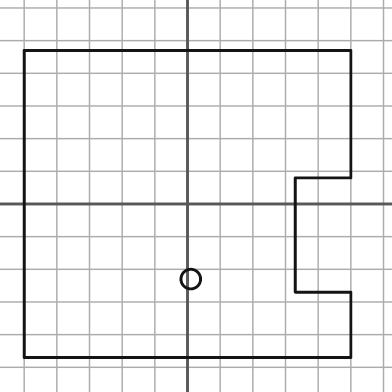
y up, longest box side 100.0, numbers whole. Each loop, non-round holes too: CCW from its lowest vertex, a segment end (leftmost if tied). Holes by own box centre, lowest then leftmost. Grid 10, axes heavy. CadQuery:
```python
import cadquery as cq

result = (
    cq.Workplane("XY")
    .moveTo(-50.0, -47.0)
    .lineTo(50.0, -47.0)
    .lineTo(50.0, -27.0)
    .lineTo(33.0, -27.0)
    .lineTo(33.0, 8.0)
    .lineTo(50.0, 8.0)
    .lineTo(50.0, 47.0)
    .lineTo(-50.0, 47.0)
    .close()
    .moveTo(1.0, -23.0)
    .circle(3.0)
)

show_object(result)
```